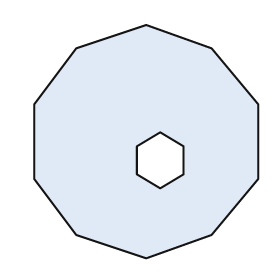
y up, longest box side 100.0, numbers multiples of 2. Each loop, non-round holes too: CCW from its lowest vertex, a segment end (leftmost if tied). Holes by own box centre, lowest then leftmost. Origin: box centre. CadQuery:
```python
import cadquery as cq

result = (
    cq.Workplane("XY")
    .moveTo(0.0, -50.0)
    .lineTo(28.0, -40.0)
    .lineTo(48.0, -16.0)
    .lineTo(48.0, 16.0)
    .lineTo(28.0, 40.0)
    .lineTo(0.0, 50.0)
    .lineTo(-30.0, 40.0)
    .lineTo(-48.0, 16.0)
    .lineTo(-48.0, -16.0)
    .lineTo(-30.0, -40.0)
    .close()
    .moveTo(6.0, -20.0)
    .lineTo(16.0, -14.0)
    .lineTo(16.0, -2.0)
    .lineTo(6.0, 4.0)
    .lineTo(-4.0, -2.0)
    .lineTo(-4.0, -14.0)
    .close()
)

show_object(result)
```